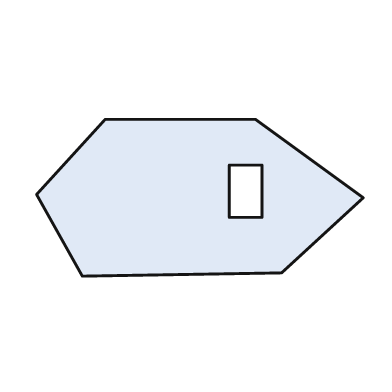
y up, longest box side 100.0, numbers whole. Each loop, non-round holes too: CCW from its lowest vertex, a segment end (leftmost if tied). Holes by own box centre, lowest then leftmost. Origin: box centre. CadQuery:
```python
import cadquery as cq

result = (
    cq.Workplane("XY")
    .moveTo(-36.0, -24.0)
    .lineTo(25.0, -23.0)
    .lineTo(50.0, 0.0)
    .lineTo(17.0, 24.0)
    .lineTo(-29.0, 24.0)
    .lineTo(-50.0, 1.0)
    .close()
    .moveTo(9.0, -6.0)
    .lineTo(19.0, -6.0)
    .lineTo(19.0, 10.0)
    .lineTo(9.0, 10.0)
    .close()
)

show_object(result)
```